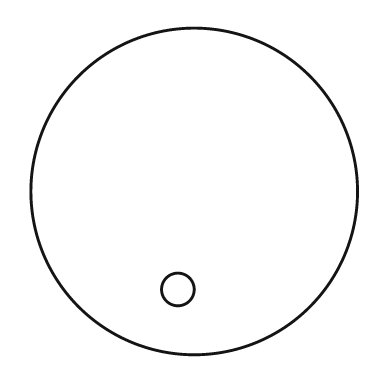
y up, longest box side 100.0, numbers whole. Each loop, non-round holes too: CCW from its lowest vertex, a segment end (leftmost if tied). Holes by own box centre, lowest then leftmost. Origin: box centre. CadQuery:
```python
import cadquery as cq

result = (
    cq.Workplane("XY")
    .moveTo(0.0, 0.0)
    .circle(50.0)
    .moveTo(-5.0, -30.0)
    .circle(5.0)
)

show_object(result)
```